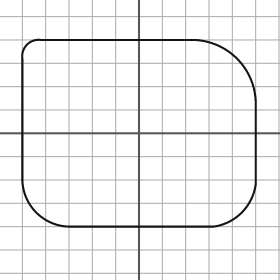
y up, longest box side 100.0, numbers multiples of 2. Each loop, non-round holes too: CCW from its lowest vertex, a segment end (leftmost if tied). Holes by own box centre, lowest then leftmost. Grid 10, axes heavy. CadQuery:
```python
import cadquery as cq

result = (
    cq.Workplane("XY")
    .moveTo(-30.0, -40.0)
    .lineTo(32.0, -40.0)
    .threePointArc((44.0, -34.0), (50.0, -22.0))
    .lineTo(50.0, 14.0)
    .threePointArc((42.0, 32.0), (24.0, 40.0))
    .lineTo(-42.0, 40.0)
    .threePointArc((-48.0, 38.0), (-50.0, 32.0))
    .lineTo(-50.0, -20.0)
    .threePointArc((-44.0, -34.0), (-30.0, -40.0))
    .close()
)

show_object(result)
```